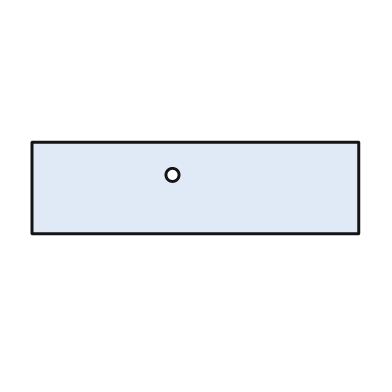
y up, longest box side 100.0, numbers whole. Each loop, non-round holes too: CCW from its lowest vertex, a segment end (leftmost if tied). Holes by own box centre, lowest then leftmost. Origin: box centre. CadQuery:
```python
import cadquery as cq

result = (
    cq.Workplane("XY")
    .moveTo(-50.0, -14.0)
    .lineTo(50.0, -14.0)
    .lineTo(50.0, 14.0)
    .lineTo(-50.0, 14.0)
    .close()
    .moveTo(-7.0, 4.0)
    .circle(2.0)
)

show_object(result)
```